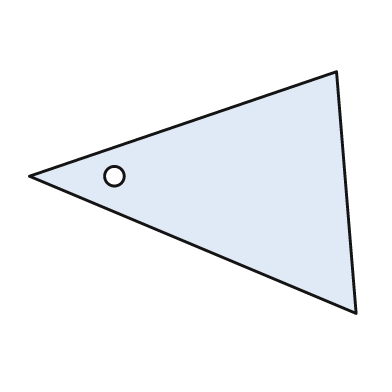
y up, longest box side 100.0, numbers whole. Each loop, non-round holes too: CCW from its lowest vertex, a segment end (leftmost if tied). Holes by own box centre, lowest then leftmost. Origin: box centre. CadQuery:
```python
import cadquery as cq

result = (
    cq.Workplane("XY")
    .moveTo(50.0, -37.0)
    .lineTo(44.0, 37.0)
    .lineTo(-50.0, 5.0)
    .close()
    .moveTo(-24.0, 5.0)
    .circle(3.0)
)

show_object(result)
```